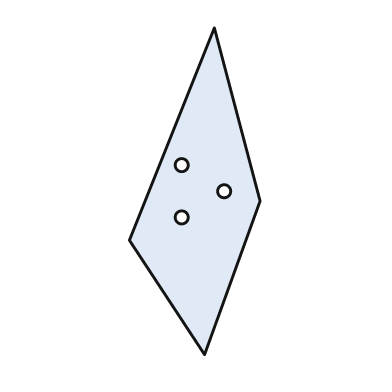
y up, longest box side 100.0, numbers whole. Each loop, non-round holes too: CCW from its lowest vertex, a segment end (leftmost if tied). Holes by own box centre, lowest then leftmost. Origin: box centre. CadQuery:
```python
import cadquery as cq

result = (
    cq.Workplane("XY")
    .moveTo(3.0, -50.0)
    .lineTo(20.0, -3.0)
    .lineTo(6.0, 50.0)
    .lineTo(-20.0, -15.0)
    .close()
    .moveTo(-4.0, -8.0)
    .circle(2.0)
    .moveTo(9.0, 0.0)
    .circle(2.0)
    .moveTo(-4.0, 8.0)
    .circle(2.0)
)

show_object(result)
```